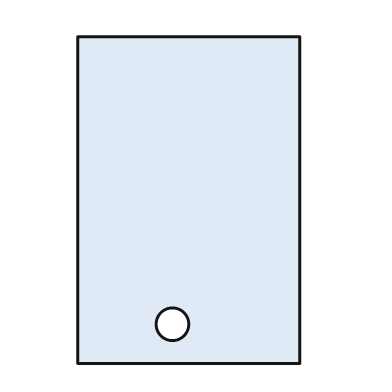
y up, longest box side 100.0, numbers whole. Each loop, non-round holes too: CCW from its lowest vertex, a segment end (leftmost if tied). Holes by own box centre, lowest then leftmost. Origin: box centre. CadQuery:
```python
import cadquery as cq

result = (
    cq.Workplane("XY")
    .moveTo(-34.0, -50.0)
    .lineTo(34.0, -50.0)
    .lineTo(34.0, 50.0)
    .lineTo(-34.0, 50.0)
    .close()
    .moveTo(-5.0, -38.0)
    .circle(5.0)
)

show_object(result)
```